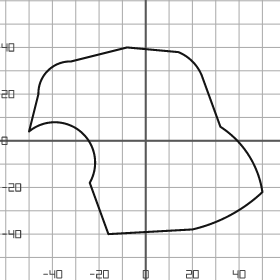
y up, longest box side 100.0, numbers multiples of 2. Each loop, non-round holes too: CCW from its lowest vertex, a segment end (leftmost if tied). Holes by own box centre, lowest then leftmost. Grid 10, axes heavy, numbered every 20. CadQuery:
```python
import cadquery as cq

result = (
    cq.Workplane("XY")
    .moveTo(-16.0, -40.0)
    .lineTo(20.0, -38.0)
    .threePointArc((36.0, -32.0), (50.0, -22.0))
    .threePointArc((44.0, -6.0), (32.0, 6.0))
    .lineTo(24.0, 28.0)
    .threePointArc((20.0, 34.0), (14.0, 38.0))
    .lineTo(-8.0, 40.0)
    .lineTo(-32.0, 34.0)
    .threePointArc((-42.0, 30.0), (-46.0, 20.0))
    .lineTo(-50.0, 4.0)
    .threePointArc((-28.0, 4.0), (-24.0, -18.0))
    .close()
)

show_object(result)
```